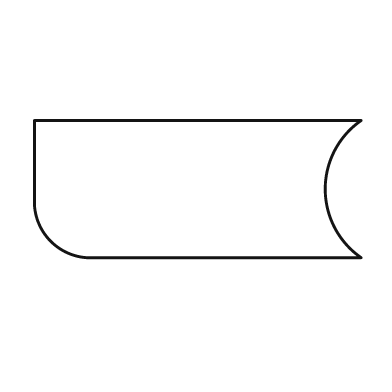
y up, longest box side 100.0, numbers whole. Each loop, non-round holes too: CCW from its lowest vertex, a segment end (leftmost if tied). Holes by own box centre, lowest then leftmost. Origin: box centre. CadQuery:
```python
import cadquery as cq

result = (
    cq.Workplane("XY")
    .moveTo(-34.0, -21.0)
    .lineTo(50.0, -21.0)
    .threePointArc((39.0, 0.0), (50.0, 21.0))
    .lineTo(-50.0, 21.0)
    .lineTo(-50.0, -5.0)
    .threePointArc((-45.0, -16.0), (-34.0, -21.0))
    .close()
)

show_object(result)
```